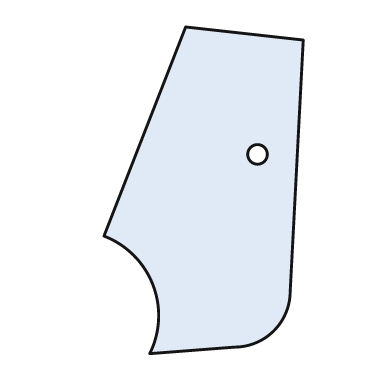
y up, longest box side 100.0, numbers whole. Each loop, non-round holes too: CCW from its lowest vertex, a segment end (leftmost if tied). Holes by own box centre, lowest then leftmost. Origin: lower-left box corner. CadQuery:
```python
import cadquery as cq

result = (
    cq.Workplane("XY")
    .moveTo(14.0, 0.0)
    .lineTo(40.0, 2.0)
    .threePointArc((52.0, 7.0), (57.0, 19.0))
    .lineTo(61.0, 96.0)
    .lineTo(25.0, 100.0)
    .lineTo(0.0, 36.0)
    .threePointArc((15.0, 21.0), (14.0, 0.0))
    .close()
    .moveTo(47.0, 61.0)
    .circle(3.0)
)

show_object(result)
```